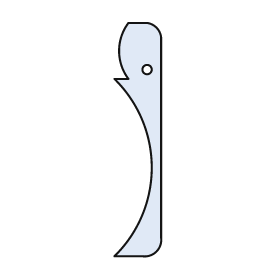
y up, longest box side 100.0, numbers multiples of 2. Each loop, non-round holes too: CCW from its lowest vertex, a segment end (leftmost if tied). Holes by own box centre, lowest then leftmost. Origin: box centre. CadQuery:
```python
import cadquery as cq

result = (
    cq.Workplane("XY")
    .moveTo(-10.0, -50.0)
    .lineTo(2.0, -50.0)
    .threePointArc((8.0, -48.0), (10.0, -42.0))
    .lineTo(10.0, 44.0)
    .threePointArc((8.0, 48.0), (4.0, 50.0))
    .lineTo(-4.0, 50.0)
    .threePointArc((-8.0, 38.0), (-4.0, 26.0))
    .lineTo(-10.0, 26.0)
    .threePointArc((6.0, -12.0), (-10.0, -50.0))
    .close()
    .moveTo(4.0, 30.0)
    .circle(2.0)
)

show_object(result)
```